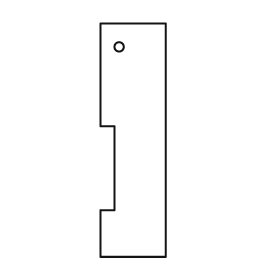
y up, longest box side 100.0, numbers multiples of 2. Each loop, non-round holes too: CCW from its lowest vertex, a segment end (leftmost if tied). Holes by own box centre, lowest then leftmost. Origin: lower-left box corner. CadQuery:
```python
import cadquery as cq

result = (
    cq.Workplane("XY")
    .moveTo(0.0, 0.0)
    .lineTo(28.0, 0.0)
    .lineTo(28.0, 100.0)
    .lineTo(0.0, 100.0)
    .lineTo(0.0, 56.0)
    .lineTo(6.0, 56.0)
    .lineTo(6.0, 20.0)
    .lineTo(0.0, 20.0)
    .close()
    .moveTo(8.0, 90.0)
    .circle(2.0)
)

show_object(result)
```